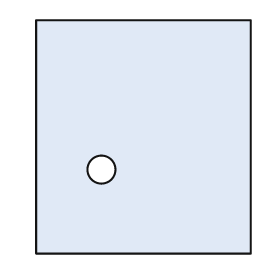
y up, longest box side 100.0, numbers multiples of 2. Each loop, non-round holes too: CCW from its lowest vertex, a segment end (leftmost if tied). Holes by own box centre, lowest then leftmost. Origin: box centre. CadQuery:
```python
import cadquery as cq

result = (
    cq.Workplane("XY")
    .moveTo(-46.0, -50.0)
    .lineTo(46.0, -50.0)
    .lineTo(46.0, 50.0)
    .lineTo(-46.0, 50.0)
    .close()
    .moveTo(-18.0, -14.0)
    .circle(6.0)
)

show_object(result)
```